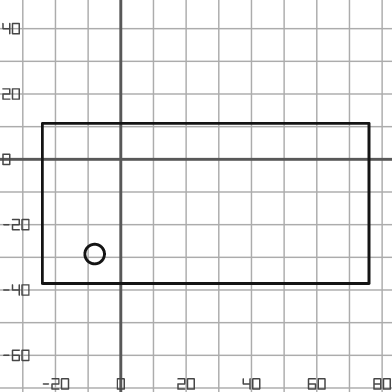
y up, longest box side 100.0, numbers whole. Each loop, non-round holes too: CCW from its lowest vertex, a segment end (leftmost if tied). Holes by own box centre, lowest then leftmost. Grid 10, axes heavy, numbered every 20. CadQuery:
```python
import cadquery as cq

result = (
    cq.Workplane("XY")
    .moveTo(-24.0, -38.0)
    .lineTo(76.0, -38.0)
    .lineTo(76.0, 11.0)
    .lineTo(-24.0, 11.0)
    .close()
    .moveTo(-8.0, -29.0)
    .circle(3.0)
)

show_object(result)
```